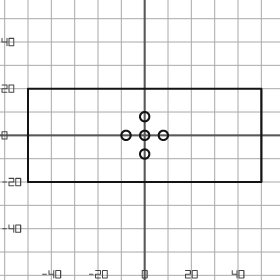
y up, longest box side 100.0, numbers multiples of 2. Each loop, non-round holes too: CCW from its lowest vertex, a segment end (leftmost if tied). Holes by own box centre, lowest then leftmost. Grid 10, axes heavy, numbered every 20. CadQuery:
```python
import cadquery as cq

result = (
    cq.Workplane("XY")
    .moveTo(-50.0, -20.0)
    .lineTo(50.0, -20.0)
    .lineTo(50.0, 20.0)
    .lineTo(-50.0, 20.0)
    .close()
    .moveTo(0.0, -8.0)
    .circle(2.0)
    .moveTo(-8.0, 0.0)
    .circle(2.0)
    .moveTo(0.0, 0.0)
    .circle(2.0)
    .moveTo(8.0, 0.0)
    .circle(2.0)
    .moveTo(0.0, 8.0)
    .circle(2.0)
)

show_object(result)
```